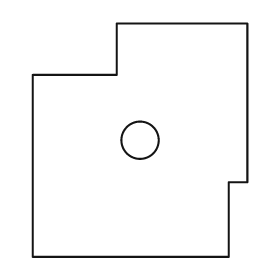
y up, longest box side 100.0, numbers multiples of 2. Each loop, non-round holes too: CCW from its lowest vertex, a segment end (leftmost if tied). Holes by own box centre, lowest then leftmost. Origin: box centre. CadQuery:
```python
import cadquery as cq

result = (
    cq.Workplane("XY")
    .moveTo(-46.0, -50.0)
    .lineTo(38.0, -50.0)
    .lineTo(38.0, -18.0)
    .lineTo(46.0, -18.0)
    .lineTo(46.0, 50.0)
    .lineTo(-10.0, 50.0)
    .lineTo(-10.0, 28.0)
    .lineTo(-46.0, 28.0)
    .close()
    .moveTo(0.0, 0.0)
    .circle(8.0)
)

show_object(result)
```